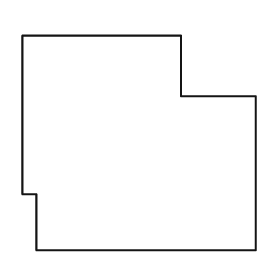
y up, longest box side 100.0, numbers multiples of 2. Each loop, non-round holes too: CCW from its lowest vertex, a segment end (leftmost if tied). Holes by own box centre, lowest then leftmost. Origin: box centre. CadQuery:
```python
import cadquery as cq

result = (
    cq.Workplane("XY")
    .moveTo(-44.0, -46.0)
    .lineTo(50.0, -46.0)
    .lineTo(50.0, 20.0)
    .lineTo(18.0, 20.0)
    .lineTo(18.0, 46.0)
    .lineTo(-50.0, 46.0)
    .lineTo(-50.0, -22.0)
    .lineTo(-44.0, -22.0)
    .close()
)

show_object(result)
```